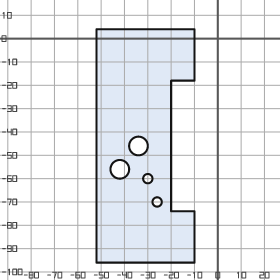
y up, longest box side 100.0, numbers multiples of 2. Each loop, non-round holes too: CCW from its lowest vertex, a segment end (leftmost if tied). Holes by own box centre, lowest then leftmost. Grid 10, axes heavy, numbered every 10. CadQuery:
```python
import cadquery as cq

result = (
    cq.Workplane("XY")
    .moveTo(-52.0, -96.0)
    .lineTo(-10.0, -96.0)
    .lineTo(-10.0, -74.0)
    .lineTo(-20.0, -74.0)
    .lineTo(-20.0, -18.0)
    .lineTo(-10.0, -18.0)
    .lineTo(-10.0, 4.0)
    .lineTo(-52.0, 4.0)
    .close()
    .moveTo(-26.0, -70.0)
    .circle(2.0)
    .moveTo(-30.0, -60.0)
    .circle(2.0)
    .moveTo(-42.0, -56.0)
    .circle(4.0)
    .moveTo(-34.0, -46.0)
    .circle(4.0)
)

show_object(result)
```